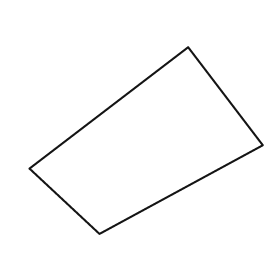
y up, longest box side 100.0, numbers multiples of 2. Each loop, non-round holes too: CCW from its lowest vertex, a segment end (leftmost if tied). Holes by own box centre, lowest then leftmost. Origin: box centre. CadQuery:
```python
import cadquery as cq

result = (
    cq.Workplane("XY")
    .moveTo(-20.0, -40.0)
    .lineTo(50.0, -2.0)
    .lineTo(18.0, 40.0)
    .lineTo(-50.0, -12.0)
    .close()
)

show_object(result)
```